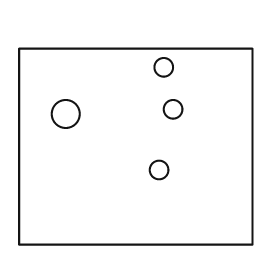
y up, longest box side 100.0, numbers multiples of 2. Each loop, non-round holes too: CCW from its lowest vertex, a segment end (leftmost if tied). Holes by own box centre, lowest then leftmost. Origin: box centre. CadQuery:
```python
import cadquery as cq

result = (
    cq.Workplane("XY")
    .moveTo(-50.0, -42.0)
    .lineTo(50.0, -42.0)
    .lineTo(50.0, 42.0)
    .lineTo(-50.0, 42.0)
    .close()
    .moveTo(10.0, -10.0)
    .circle(4.0)
    .moveTo(-30.0, 14.0)
    .circle(6.0)
    .moveTo(16.0, 16.0)
    .circle(4.0)
    .moveTo(12.0, 34.0)
    .circle(4.0)
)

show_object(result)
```